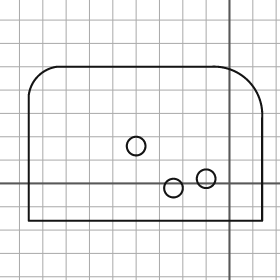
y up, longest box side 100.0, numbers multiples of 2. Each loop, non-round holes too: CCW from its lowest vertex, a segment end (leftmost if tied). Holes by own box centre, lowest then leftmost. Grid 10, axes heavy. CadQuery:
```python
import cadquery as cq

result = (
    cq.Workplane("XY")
    .moveTo(-86.0, -16.0)
    .lineTo(14.0, -16.0)
    .lineTo(14.0, 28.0)
    .threePointArc((8.0, 44.0), (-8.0, 50.0))
    .lineTo(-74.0, 50.0)
    .threePointArc((-82.0, 46.0), (-86.0, 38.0))
    .close()
    .moveTo(-24.0, -2.0)
    .circle(4.0)
    .moveTo(-10.0, 2.0)
    .circle(4.0)
    .moveTo(-40.0, 16.0)
    .circle(4.0)
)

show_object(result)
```